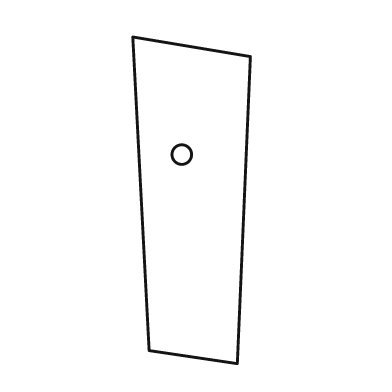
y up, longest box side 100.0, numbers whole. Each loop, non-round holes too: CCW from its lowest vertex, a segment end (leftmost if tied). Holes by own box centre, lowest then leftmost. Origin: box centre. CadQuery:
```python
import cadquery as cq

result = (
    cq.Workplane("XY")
    .moveTo(14.0, -50.0)
    .lineTo(18.0, 44.0)
    .lineTo(-18.0, 50.0)
    .lineTo(-13.0, -46.0)
    .close()
    .moveTo(-3.0, 14.0)
    .circle(3.0)
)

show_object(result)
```